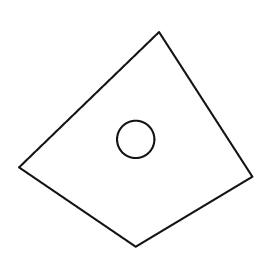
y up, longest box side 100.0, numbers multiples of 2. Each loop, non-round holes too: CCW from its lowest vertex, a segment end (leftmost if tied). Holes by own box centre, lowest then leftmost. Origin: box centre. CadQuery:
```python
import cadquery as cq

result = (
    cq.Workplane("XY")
    .moveTo(0.0, -46.0)
    .lineTo(50.0, -16.0)
    .lineTo(10.0, 46.0)
    .lineTo(-50.0, -12.0)
    .close()
    .moveTo(0.0, 0.0)
    .circle(8.0)
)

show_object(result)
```